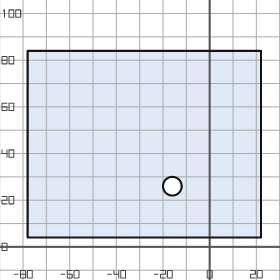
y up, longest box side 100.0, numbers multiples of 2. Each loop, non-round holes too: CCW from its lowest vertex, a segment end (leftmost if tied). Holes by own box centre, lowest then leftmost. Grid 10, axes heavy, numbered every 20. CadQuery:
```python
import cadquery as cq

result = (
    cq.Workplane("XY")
    .moveTo(-78.0, 4.0)
    .lineTo(22.0, 4.0)
    .lineTo(22.0, 84.0)
    .lineTo(-78.0, 84.0)
    .close()
    .moveTo(-16.0, 26.0)
    .circle(4.0)
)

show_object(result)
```